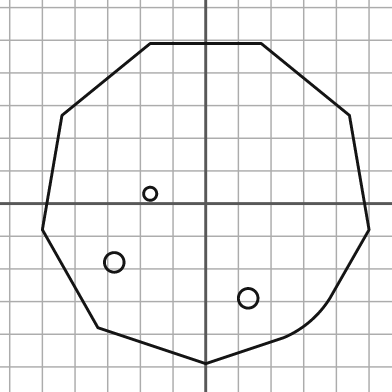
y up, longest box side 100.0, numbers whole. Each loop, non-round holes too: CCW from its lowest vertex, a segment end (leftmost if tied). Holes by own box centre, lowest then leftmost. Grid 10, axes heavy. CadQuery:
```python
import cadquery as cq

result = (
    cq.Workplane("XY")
    .moveTo(0.0, -49.0)
    .lineTo(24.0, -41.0)
    .threePointArc((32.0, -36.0), (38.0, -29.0))
    .lineTo(50.0, -8.0)
    .lineTo(44.0, 27.0)
    .lineTo(17.0, 49.0)
    .lineTo(-17.0, 49.0)
    .lineTo(-44.0, 27.0)
    .lineTo(-50.0, -8.0)
    .lineTo(-33.0, -38.0)
    .close()
    .moveTo(13.0, -29.0)
    .circle(3.0)
    .moveTo(-28.0, -18.0)
    .circle(3.0)
    .moveTo(-17.0, 3.0)
    .circle(2.0)
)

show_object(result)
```